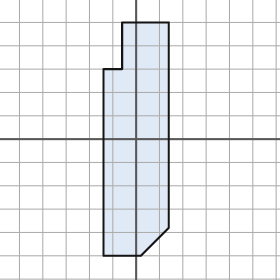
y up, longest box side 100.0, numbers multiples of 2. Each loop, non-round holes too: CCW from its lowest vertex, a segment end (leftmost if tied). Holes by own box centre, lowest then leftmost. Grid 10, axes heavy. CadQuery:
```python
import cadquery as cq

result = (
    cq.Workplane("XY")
    .moveTo(-14.0, -50.0)
    .lineTo(2.0, -50.0)
    .lineTo(14.0, -38.0)
    .lineTo(14.0, 50.0)
    .lineTo(-6.0, 50.0)
    .lineTo(-6.0, 30.0)
    .lineTo(-14.0, 30.0)
    .close()
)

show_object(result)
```